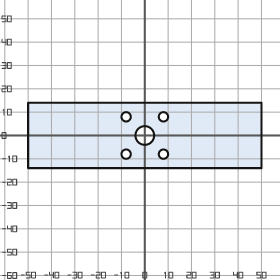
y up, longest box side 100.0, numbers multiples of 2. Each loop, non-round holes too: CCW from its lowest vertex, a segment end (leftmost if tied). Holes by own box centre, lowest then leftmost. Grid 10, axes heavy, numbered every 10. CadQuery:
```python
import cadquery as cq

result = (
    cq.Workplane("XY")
    .moveTo(-50.0, -14.0)
    .lineTo(50.0, -14.0)
    .lineTo(50.0, 14.0)
    .lineTo(-50.0, 14.0)
    .close()
    .moveTo(-8.0, -8.0)
    .circle(2.0)
    .moveTo(8.0, -8.0)
    .circle(2.0)
    .moveTo(0.0, 0.0)
    .circle(4.0)
    .moveTo(-8.0, 8.0)
    .circle(2.0)
    .moveTo(8.0, 8.0)
    .circle(2.0)
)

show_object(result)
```